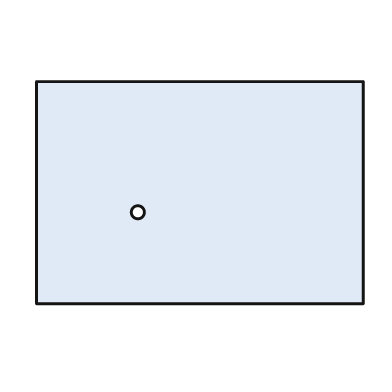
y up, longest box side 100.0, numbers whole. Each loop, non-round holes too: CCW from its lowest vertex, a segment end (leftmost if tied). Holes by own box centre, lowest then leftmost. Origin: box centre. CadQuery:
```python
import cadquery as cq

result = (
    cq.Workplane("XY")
    .moveTo(-50.0, -34.0)
    .lineTo(50.0, -34.0)
    .lineTo(50.0, 34.0)
    .lineTo(-50.0, 34.0)
    .close()
    .moveTo(-19.0, -6.0)
    .circle(2.0)
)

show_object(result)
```